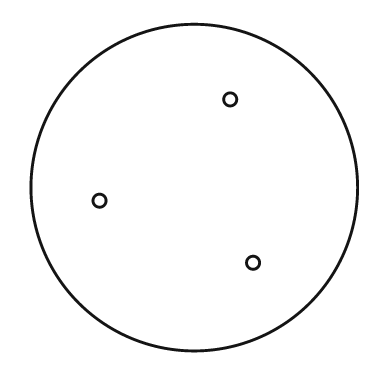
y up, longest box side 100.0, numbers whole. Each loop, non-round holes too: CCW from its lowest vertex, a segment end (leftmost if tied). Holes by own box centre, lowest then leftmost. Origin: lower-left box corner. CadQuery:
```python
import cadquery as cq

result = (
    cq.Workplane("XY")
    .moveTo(50.0, 50.0)
    .circle(50.0)
    .moveTo(68.0, 27.0)
    .circle(2.0)
    .moveTo(21.0, 46.0)
    .circle(2.0)
    .moveTo(61.0, 77.0)
    .circle(2.0)
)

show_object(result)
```